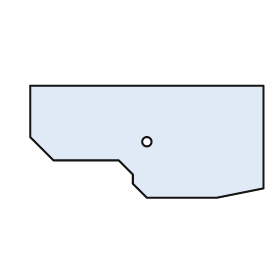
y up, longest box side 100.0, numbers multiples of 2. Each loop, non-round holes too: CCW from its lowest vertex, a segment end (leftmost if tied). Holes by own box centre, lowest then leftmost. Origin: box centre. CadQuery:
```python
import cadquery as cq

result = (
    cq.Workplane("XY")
    .moveTo(0.0, -24.0)
    .lineTo(30.0, -24.0)
    .lineTo(50.0, -20.0)
    .lineTo(50.0, 24.0)
    .lineTo(-50.0, 24.0)
    .lineTo(-50.0, 2.0)
    .lineTo(-40.0, -8.0)
    .lineTo(-12.0, -8.0)
    .lineTo(-6.0, -14.0)
    .lineTo(-6.0, -18.0)
    .close()
    .moveTo(0.0, 0.0)
    .circle(2.0)
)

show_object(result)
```